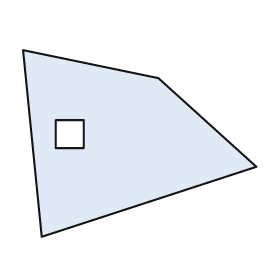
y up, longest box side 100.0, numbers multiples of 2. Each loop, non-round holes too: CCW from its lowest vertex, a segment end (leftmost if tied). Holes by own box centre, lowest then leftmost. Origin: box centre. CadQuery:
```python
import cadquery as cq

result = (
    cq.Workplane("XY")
    .moveTo(-42.0, -40.0)
    .lineTo(50.0, -10.0)
    .lineTo(8.0, 28.0)
    .lineTo(-50.0, 40.0)
    .close()
    .moveTo(-36.0, -2.0)
    .lineTo(-24.0, -2.0)
    .lineTo(-24.0, 10.0)
    .lineTo(-36.0, 10.0)
    .close()
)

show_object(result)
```